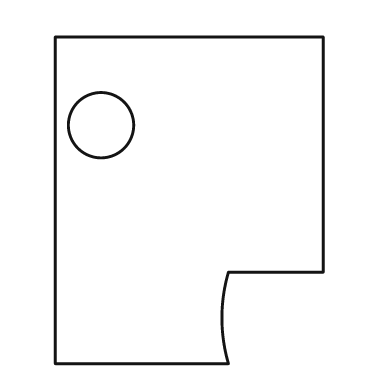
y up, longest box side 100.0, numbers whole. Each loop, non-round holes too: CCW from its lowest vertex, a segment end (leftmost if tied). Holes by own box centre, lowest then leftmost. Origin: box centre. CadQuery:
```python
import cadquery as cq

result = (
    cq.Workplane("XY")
    .moveTo(-41.0, -50.0)
    .lineTo(12.0, -50.0)
    .threePointArc((10.0, -36.0), (12.0, -22.0))
    .lineTo(41.0, -22.0)
    .lineTo(41.0, 50.0)
    .lineTo(-41.0, 50.0)
    .close()
    .moveTo(-27.0, 23.0)
    .circle(10.0)
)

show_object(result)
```